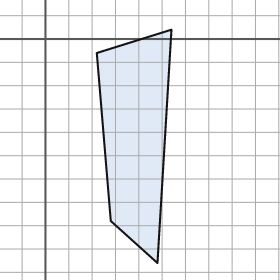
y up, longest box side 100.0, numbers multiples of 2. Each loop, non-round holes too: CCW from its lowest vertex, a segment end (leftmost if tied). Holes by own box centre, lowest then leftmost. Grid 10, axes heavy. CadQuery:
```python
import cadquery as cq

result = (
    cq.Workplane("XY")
    .moveTo(48.0, -96.0)
    .lineTo(54.0, 4.0)
    .lineTo(22.0, -6.0)
    .lineTo(28.0, -78.0)
    .close()
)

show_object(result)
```